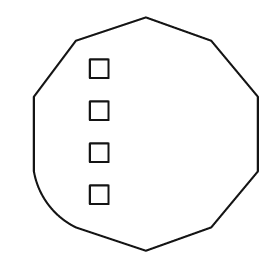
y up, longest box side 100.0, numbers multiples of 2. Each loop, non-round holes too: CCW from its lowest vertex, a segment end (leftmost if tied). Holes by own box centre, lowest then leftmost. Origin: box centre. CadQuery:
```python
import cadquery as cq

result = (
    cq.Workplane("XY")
    .moveTo(0.0, -50.0)
    .lineTo(28.0, -40.0)
    .lineTo(48.0, -16.0)
    .lineTo(48.0, 16.0)
    .lineTo(28.0, 40.0)
    .lineTo(0.0, 50.0)
    .lineTo(-30.0, 40.0)
    .lineTo(-48.0, 16.0)
    .lineTo(-48.0, -16.0)
    .threePointArc((-42.0, -30.0), (-30.0, -40.0))
    .close()
    .moveTo(-24.0, -30.0)
    .lineTo(-16.0, -30.0)
    .lineTo(-16.0, -22.0)
    .lineTo(-24.0, -22.0)
    .close()
    .moveTo(-24.0, -12.0)
    .lineTo(-16.0, -12.0)
    .lineTo(-16.0, -4.0)
    .lineTo(-24.0, -4.0)
    .close()
    .moveTo(-24.0, 6.0)
    .lineTo(-16.0, 6.0)
    .lineTo(-16.0, 14.0)
    .lineTo(-24.0, 14.0)
    .close()
    .moveTo(-24.0, 24.0)
    .lineTo(-16.0, 24.0)
    .lineTo(-16.0, 32.0)
    .lineTo(-24.0, 32.0)
    .close()
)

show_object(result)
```